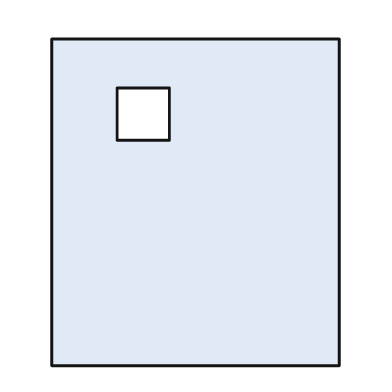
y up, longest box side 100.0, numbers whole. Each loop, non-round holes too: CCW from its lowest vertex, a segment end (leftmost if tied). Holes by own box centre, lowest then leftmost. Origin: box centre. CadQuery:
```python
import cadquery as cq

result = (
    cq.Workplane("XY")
    .moveTo(-44.0, -50.0)
    .lineTo(44.0, -50.0)
    .lineTo(44.0, 50.0)
    .lineTo(-44.0, 50.0)
    .close()
    .moveTo(-24.0, 19.0)
    .lineTo(-8.0, 19.0)
    .lineTo(-8.0, 35.0)
    .lineTo(-24.0, 35.0)
    .close()
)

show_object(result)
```